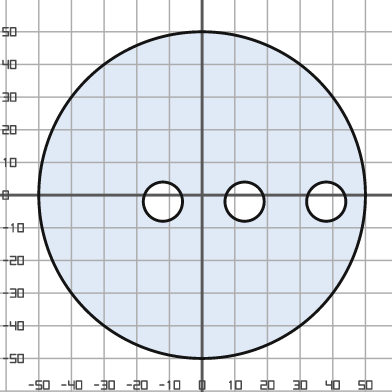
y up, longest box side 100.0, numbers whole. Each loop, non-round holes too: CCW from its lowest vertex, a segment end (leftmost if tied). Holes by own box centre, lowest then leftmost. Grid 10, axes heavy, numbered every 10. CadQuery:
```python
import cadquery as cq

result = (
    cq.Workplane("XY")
    .moveTo(0.0, 0.0)
    .circle(50.0)
    .moveTo(-12.0, -2.0)
    .circle(6.0)
    .moveTo(13.0, -2.0)
    .circle(6.0)
    .moveTo(38.0, -2.0)
    .circle(6.0)
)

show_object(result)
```